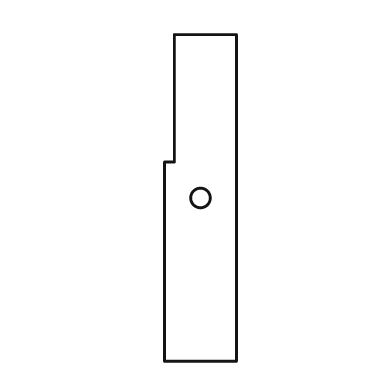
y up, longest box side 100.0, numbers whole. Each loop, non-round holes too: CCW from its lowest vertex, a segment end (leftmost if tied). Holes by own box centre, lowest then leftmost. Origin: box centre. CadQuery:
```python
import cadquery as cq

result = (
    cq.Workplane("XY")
    .moveTo(-11.0, -50.0)
    .lineTo(11.0, -50.0)
    .lineTo(11.0, 50.0)
    .lineTo(-8.0, 50.0)
    .lineTo(-8.0, 11.0)
    .lineTo(-11.0, 11.0)
    .close()
    .moveTo(0.0, 0.0)
    .circle(3.0)
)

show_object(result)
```